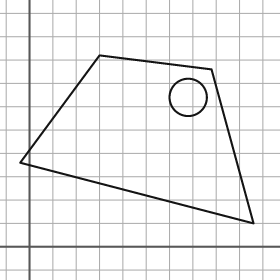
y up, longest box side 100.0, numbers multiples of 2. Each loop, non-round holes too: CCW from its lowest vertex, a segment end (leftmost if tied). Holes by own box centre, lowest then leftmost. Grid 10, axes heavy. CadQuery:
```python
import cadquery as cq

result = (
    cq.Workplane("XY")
    .moveTo(96.0, 10.0)
    .lineTo(78.0, 76.0)
    .lineTo(30.0, 82.0)
    .lineTo(-4.0, 36.0)
    .close()
    .moveTo(68.0, 64.0)
    .circle(8.0)
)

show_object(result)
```